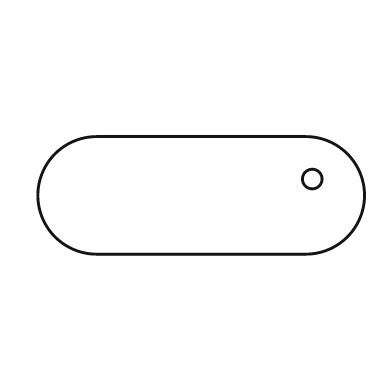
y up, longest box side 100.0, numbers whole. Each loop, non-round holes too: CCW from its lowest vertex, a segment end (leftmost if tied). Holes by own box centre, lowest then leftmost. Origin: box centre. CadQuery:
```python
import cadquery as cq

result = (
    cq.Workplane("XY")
    .moveTo(-32.0, -18.0)
    .lineTo(32.0, -18.0)
    .threePointArc((50.0, 0.0), (32.0, 18.0))
    .lineTo(-32.0, 18.0)
    .threePointArc((-50.0, 0.0), (-32.0, -18.0))
    .close()
    .moveTo(34.0, 5.0)
    .circle(3.0)
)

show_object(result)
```